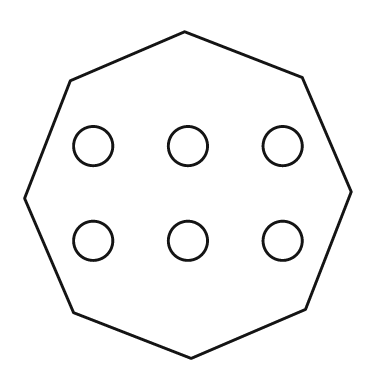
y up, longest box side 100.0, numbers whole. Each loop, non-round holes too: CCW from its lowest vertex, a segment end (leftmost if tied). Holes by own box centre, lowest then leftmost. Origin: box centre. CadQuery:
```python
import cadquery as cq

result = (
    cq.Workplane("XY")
    .moveTo(1.0, -50.0)
    .lineTo(36.0, -35.0)
    .lineTo(50.0, 1.0)
    .lineTo(35.0, 36.0)
    .lineTo(-1.0, 50.0)
    .lineTo(-36.0, 35.0)
    .lineTo(-50.0, -1.0)
    .lineTo(-35.0, -36.0)
    .close()
    .moveTo(-29.0, -14.0)
    .circle(6.0)
    .moveTo(0.0, -14.0)
    .circle(6.0)
    .moveTo(29.0, -14.0)
    .circle(6.0)
    .moveTo(-29.0, 15.0)
    .circle(6.0)
    .moveTo(0.0, 15.0)
    .circle(6.0)
    .moveTo(29.0, 15.0)
    .circle(6.0)
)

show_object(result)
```